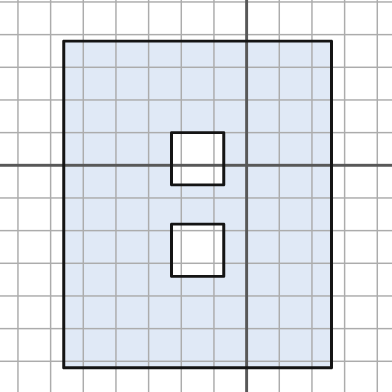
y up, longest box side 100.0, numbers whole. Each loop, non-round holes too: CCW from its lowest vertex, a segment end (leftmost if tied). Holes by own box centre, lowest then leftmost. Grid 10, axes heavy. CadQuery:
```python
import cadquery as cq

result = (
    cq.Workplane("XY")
    .moveTo(-56.0, -62.0)
    .lineTo(26.0, -62.0)
    .lineTo(26.0, 38.0)
    .lineTo(-56.0, 38.0)
    .close()
    .moveTo(-23.0, -34.0)
    .lineTo(-7.0, -34.0)
    .lineTo(-7.0, -18.0)
    .lineTo(-23.0, -18.0)
    .close()
    .moveTo(-23.0, -6.0)
    .lineTo(-7.0, -6.0)
    .lineTo(-7.0, 10.0)
    .lineTo(-23.0, 10.0)
    .close()
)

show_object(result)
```